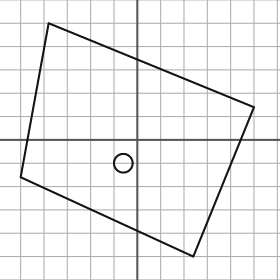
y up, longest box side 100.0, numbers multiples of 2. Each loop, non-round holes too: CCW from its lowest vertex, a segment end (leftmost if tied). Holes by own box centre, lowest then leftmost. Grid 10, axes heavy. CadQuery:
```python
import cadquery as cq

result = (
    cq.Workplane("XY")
    .moveTo(24.0, -50.0)
    .lineTo(50.0, 14.0)
    .lineTo(-38.0, 50.0)
    .lineTo(-50.0, -16.0)
    .close()
    .moveTo(-6.0, -10.0)
    .circle(4.0)
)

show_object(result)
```